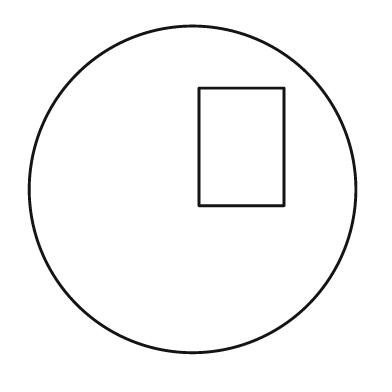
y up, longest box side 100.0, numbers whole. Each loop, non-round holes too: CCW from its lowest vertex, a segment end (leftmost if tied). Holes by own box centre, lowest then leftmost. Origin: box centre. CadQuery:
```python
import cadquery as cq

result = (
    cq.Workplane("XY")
    .moveTo(0.0, 0.0)
    .circle(50.0)
    .moveTo(2.0, -5.0)
    .lineTo(28.0, -5.0)
    .lineTo(28.0, 31.0)
    .lineTo(2.0, 31.0)
    .close()
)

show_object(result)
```